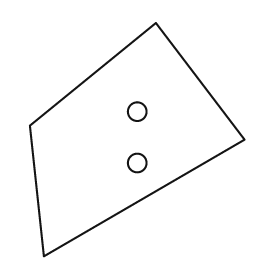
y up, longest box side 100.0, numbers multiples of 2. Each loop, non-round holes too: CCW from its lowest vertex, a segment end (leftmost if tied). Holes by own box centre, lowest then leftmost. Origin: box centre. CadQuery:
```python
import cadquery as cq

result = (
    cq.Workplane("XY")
    .moveTo(-40.0, -50.0)
    .lineTo(46.0, 0.0)
    .lineTo(8.0, 50.0)
    .lineTo(-46.0, 6.0)
    .close()
    .moveTo(0.0, -10.0)
    .circle(4.0)
    .moveTo(0.0, 12.0)
    .circle(4.0)
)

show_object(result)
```